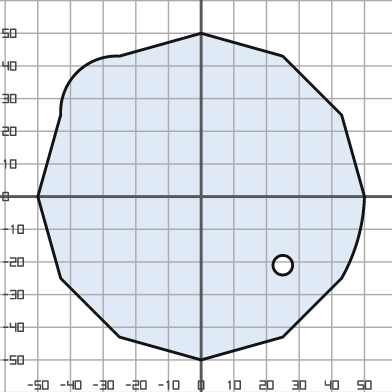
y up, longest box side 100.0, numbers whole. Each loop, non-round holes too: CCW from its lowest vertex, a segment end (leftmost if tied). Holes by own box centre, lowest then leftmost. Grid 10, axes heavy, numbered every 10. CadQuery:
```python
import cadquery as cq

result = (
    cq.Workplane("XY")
    .moveTo(0.0, -50.0)
    .lineTo(25.0, -43.0)
    .lineTo(43.0, -25.0)
    .threePointArc((48.0, -13.0), (50.0, 0.0))
    .lineTo(43.0, 25.0)
    .lineTo(25.0, 43.0)
    .lineTo(0.0, 50.0)
    .lineTo(-25.0, 43.0)
    .threePointArc((-38.0, 38.0), (-43.0, 25.0))
    .lineTo(-50.0, 0.0)
    .lineTo(-43.0, -25.0)
    .lineTo(-25.0, -43.0)
    .close()
    .moveTo(25.0, -21.0)
    .circle(3.0)
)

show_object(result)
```